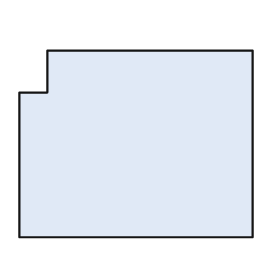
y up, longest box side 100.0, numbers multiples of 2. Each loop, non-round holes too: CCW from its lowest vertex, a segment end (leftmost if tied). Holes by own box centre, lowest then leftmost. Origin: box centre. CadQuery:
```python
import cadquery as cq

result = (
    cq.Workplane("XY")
    .moveTo(-50.0, -40.0)
    .lineTo(50.0, -40.0)
    .lineTo(50.0, 40.0)
    .lineTo(-38.0, 40.0)
    .lineTo(-38.0, 22.0)
    .lineTo(-50.0, 22.0)
    .close()
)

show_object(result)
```